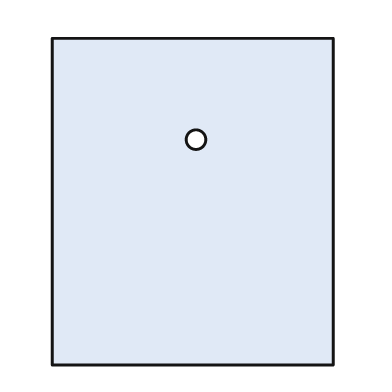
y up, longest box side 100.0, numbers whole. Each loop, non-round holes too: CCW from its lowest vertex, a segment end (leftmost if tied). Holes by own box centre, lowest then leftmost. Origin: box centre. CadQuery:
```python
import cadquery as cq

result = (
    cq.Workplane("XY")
    .moveTo(-43.0, -50.0)
    .lineTo(43.0, -50.0)
    .lineTo(43.0, 50.0)
    .lineTo(-43.0, 50.0)
    .close()
    .moveTo(1.0, 19.0)
    .circle(3.0)
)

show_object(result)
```